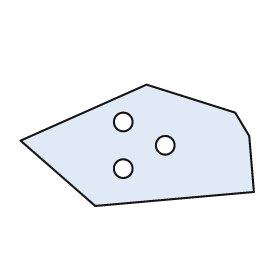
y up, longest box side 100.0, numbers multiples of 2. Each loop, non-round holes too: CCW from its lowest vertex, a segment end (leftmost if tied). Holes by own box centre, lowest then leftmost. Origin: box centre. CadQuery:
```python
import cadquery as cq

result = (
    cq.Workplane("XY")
    .moveTo(-18.0, -26.0)
    .lineTo(50.0, -20.0)
    .lineTo(48.0, 4.0)
    .lineTo(42.0, 14.0)
    .lineTo(4.0, 26.0)
    .lineTo(-50.0, 2.0)
    .close()
    .moveTo(-6.0, -10.0)
    .circle(4.0)
    .moveTo(12.0, 0.0)
    .circle(4.0)
    .moveTo(-6.0, 10.0)
    .circle(4.0)
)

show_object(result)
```